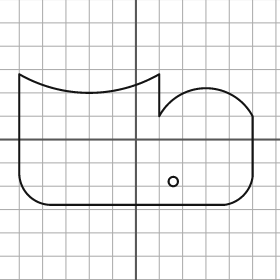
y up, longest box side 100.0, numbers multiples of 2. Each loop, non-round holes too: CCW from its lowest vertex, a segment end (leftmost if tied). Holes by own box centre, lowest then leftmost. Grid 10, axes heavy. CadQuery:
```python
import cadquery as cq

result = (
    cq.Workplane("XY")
    .moveTo(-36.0, -28.0)
    .lineTo(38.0, -28.0)
    .threePointArc((46.0, -24.0), (50.0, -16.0))
    .lineTo(50.0, 10.0)
    .threePointArc((30.0, 22.0), (10.0, 10.0))
    .lineTo(10.0, 28.0)
    .threePointArc((-20.0, 20.0), (-50.0, 28.0))
    .lineTo(-50.0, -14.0)
    .threePointArc((-46.0, -24.0), (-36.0, -28.0))
    .close()
    .moveTo(16.0, -18.0)
    .circle(2.0)
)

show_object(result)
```